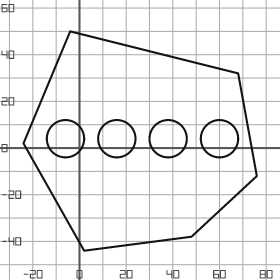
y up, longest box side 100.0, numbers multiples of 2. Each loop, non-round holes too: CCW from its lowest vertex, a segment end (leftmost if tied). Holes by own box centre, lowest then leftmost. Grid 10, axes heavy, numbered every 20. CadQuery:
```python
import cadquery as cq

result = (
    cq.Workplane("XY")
    .moveTo(2.0, -44.0)
    .lineTo(48.0, -38.0)
    .lineTo(76.0, -12.0)
    .lineTo(68.0, 32.0)
    .lineTo(-4.0, 50.0)
    .lineTo(-24.0, 2.0)
    .close()
    .moveTo(-6.0, 4.0)
    .circle(8.0)
    .moveTo(16.0, 4.0)
    .circle(8.0)
    .moveTo(38.0, 4.0)
    .circle(8.0)
    .moveTo(60.0, 4.0)
    .circle(8.0)
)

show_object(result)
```